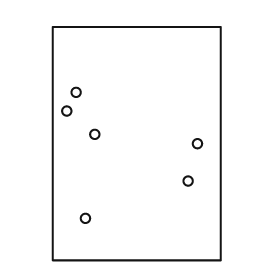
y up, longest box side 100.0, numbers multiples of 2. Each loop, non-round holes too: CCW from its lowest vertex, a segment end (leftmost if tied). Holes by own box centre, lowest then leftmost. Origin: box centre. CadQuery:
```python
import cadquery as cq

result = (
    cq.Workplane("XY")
    .moveTo(-36.0, -50.0)
    .lineTo(36.0, -50.0)
    .lineTo(36.0, 50.0)
    .lineTo(-36.0, 50.0)
    .close()
    .moveTo(-22.0, -32.0)
    .circle(2.0)
    .moveTo(22.0, -16.0)
    .circle(2.0)
    .moveTo(26.0, 0.0)
    .circle(2.0)
    .moveTo(-18.0, 4.0)
    .circle(2.0)
    .moveTo(-30.0, 14.0)
    .circle(2.0)
    .moveTo(-26.0, 22.0)
    .circle(2.0)
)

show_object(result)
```